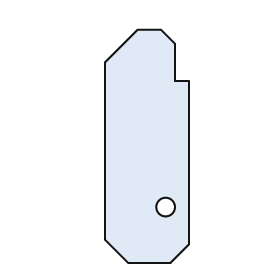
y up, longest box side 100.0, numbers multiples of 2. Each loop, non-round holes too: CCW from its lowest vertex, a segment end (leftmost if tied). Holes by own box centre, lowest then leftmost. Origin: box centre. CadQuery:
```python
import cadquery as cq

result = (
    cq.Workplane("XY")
    .moveTo(-8.0, -50.0)
    .lineTo(10.0, -50.0)
    .lineTo(18.0, -42.0)
    .lineTo(18.0, 28.0)
    .lineTo(12.0, 28.0)
    .lineTo(12.0, 44.0)
    .lineTo(6.0, 50.0)
    .lineTo(-4.0, 50.0)
    .lineTo(-18.0, 36.0)
    .lineTo(-18.0, -40.0)
    .close()
    .moveTo(8.0, -26.0)
    .circle(4.0)
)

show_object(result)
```